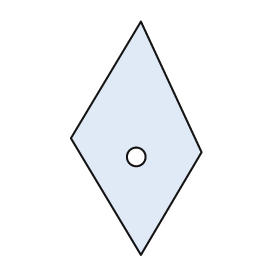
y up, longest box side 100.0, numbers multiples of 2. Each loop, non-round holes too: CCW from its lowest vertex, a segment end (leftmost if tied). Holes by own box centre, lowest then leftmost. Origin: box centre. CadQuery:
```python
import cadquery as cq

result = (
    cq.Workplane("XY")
    .moveTo(2.0, -50.0)
    .lineTo(28.0, -6.0)
    .lineTo(2.0, 50.0)
    .lineTo(-28.0, 0.0)
    .close()
    .moveTo(0.0, -8.0)
    .circle(4.0)
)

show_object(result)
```